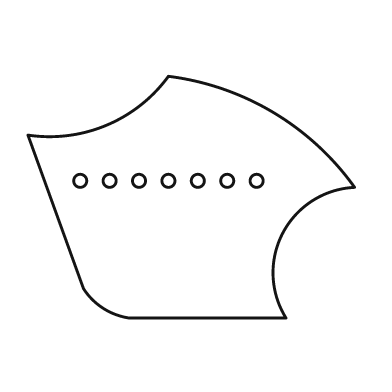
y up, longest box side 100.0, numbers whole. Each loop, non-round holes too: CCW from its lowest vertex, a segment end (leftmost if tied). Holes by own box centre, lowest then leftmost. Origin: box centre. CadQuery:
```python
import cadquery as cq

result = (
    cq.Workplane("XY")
    .moveTo(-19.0, -37.0)
    .lineTo(29.0, -37.0)
    .threePointArc((28.0, -11.0), (50.0, 3.0))
    .threePointArc((25.0, 26.0), (-7.0, 37.0))
    .threePointArc((-26.0, 22.0), (-50.0, 19.0))
    .lineTo(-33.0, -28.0)
    .threePointArc((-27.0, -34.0), (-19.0, -37.0))
    .close()
    .moveTo(-34.0, 5.0)
    .circle(2.0)
    .moveTo(-25.0, 5.0)
    .circle(2.0)
    .moveTo(-16.0, 5.0)
    .circle(2.0)
    .moveTo(-7.0, 5.0)
    .circle(2.0)
    .moveTo(2.0, 5.0)
    .circle(2.0)
    .moveTo(11.0, 5.0)
    .circle(2.0)
    .moveTo(20.0, 5.0)
    .circle(2.0)
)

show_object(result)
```